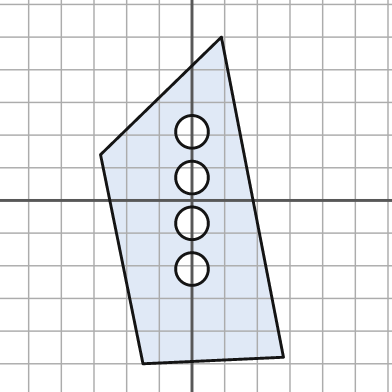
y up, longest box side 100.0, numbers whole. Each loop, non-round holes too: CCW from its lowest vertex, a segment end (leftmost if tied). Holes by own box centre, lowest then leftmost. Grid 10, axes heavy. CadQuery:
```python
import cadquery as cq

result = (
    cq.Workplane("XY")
    .moveTo(-15.0, -50.0)
    .lineTo(28.0, -48.0)
    .lineTo(9.0, 50.0)
    .lineTo(-28.0, 14.0)
    .close()
    .moveTo(0.0, -21.0)
    .circle(5.0)
    .moveTo(0.0, -7.0)
    .circle(5.0)
    .moveTo(0.0, 7.0)
    .circle(5.0)
    .moveTo(0.0, 21.0)
    .circle(5.0)
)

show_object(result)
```